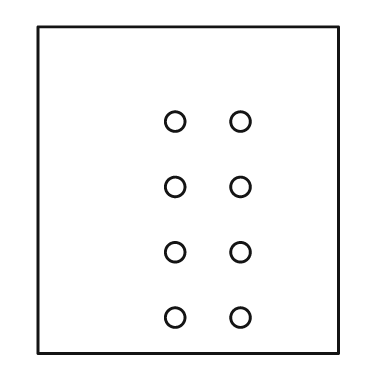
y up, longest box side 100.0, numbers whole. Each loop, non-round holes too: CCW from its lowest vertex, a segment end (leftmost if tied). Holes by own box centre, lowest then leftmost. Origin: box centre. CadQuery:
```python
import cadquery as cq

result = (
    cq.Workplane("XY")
    .moveTo(-46.0, -50.0)
    .lineTo(46.0, -50.0)
    .lineTo(46.0, 50.0)
    .lineTo(-46.0, 50.0)
    .close()
    .moveTo(-4.0, -39.0)
    .circle(3.0)
    .moveTo(16.0, -39.0)
    .circle(3.0)
    .moveTo(-4.0, -19.0)
    .circle(3.0)
    .moveTo(16.0, -19.0)
    .circle(3.0)
    .moveTo(-4.0, 1.0)
    .circle(3.0)
    .moveTo(16.0, 1.0)
    .circle(3.0)
    .moveTo(-4.0, 21.0)
    .circle(3.0)
    .moveTo(16.0, 21.0)
    .circle(3.0)
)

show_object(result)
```